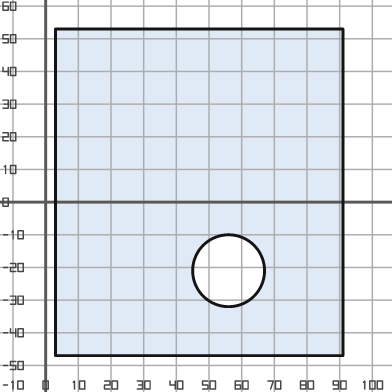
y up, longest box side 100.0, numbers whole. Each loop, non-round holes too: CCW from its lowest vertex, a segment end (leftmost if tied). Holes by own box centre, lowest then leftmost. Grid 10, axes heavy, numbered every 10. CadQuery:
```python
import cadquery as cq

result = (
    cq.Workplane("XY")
    .moveTo(3.0, -47.0)
    .lineTo(91.0, -47.0)
    .lineTo(91.0, 53.0)
    .lineTo(3.0, 53.0)
    .close()
    .moveTo(56.0, -21.0)
    .circle(11.0)
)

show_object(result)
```